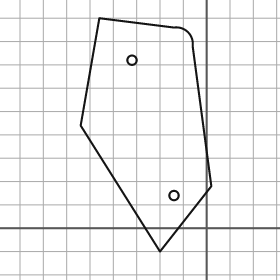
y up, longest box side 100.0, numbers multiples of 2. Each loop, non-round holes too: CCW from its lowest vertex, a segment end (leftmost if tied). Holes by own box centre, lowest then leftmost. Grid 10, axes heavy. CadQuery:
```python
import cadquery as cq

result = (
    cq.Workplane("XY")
    .moveTo(-20.0, -10.0)
    .lineTo(2.0, 18.0)
    .lineTo(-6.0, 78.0)
    .threePointArc((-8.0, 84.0), (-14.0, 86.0))
    .lineTo(-46.0, 90.0)
    .lineTo(-54.0, 44.0)
    .close()
    .moveTo(-14.0, 14.0)
    .circle(2.0)
    .moveTo(-32.0, 72.0)
    .circle(2.0)
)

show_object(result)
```